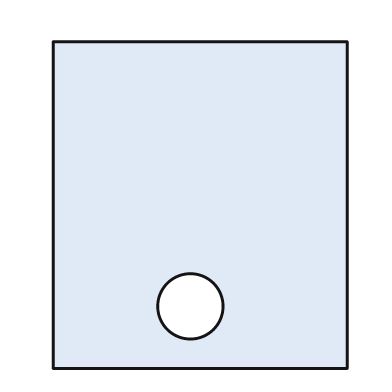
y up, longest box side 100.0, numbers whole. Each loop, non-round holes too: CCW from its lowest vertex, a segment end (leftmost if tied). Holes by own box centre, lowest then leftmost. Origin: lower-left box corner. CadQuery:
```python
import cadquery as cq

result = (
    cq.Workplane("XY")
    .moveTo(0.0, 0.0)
    .lineTo(90.0, 0.0)
    .lineTo(90.0, 100.0)
    .lineTo(0.0, 100.0)
    .close()
    .moveTo(42.0, 19.0)
    .circle(10.0)
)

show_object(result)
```